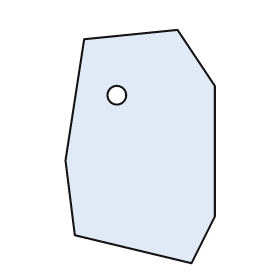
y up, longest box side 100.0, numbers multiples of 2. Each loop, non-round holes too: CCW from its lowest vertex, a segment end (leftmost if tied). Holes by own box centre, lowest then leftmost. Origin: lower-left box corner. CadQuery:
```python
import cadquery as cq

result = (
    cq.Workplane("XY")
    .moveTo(54.0, 0.0)
    .lineTo(64.0, 20.0)
    .lineTo(64.0, 76.0)
    .lineTo(48.0, 100.0)
    .lineTo(8.0, 96.0)
    .lineTo(0.0, 44.0)
    .lineTo(4.0, 12.0)
    .close()
    .moveTo(22.0, 72.0)
    .circle(4.0)
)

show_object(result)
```